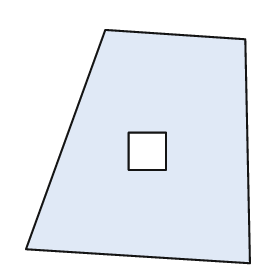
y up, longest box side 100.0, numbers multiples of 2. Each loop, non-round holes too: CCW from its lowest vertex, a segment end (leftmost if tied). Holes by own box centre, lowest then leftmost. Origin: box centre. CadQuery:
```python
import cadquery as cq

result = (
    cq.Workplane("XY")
    .moveTo(48.0, -50.0)
    .lineTo(46.0, 46.0)
    .lineTo(-14.0, 50.0)
    .lineTo(-48.0, -44.0)
    .close()
    .moveTo(-4.0, -10.0)
    .lineTo(12.0, -10.0)
    .lineTo(12.0, 6.0)
    .lineTo(-4.0, 6.0)
    .close()
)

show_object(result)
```